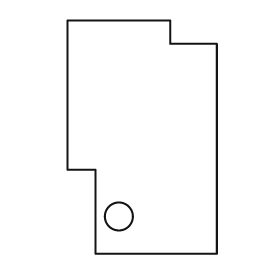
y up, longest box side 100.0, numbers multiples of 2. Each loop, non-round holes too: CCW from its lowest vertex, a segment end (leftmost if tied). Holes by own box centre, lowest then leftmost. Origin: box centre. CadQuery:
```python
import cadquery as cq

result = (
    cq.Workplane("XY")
    .moveTo(-20.0, -50.0)
    .lineTo(32.0, -50.0)
    .lineTo(32.0, 40.0)
    .lineTo(12.0, 40.0)
    .lineTo(12.0, 50.0)
    .lineTo(-32.0, 50.0)
    .lineTo(-32.0, -14.0)
    .lineTo(-20.0, -14.0)
    .close()
    .moveTo(-10.0, -34.0)
    .circle(6.0)
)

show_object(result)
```